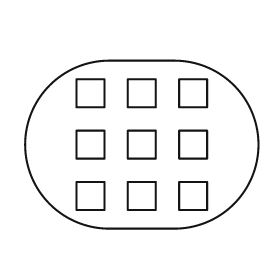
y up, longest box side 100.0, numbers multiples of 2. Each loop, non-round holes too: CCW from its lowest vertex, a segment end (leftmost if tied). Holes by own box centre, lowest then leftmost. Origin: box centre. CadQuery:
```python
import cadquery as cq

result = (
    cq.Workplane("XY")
    .moveTo(-14.0, -36.0)
    .lineTo(14.0, -36.0)
    .threePointArc((50.0, 0.0), (14.0, 36.0))
    .lineTo(-14.0, 36.0)
    .threePointArc((-50.0, 0.0), (-14.0, -36.0))
    .close()
    .moveTo(-28.0, -28.0)
    .lineTo(-16.0, -28.0)
    .lineTo(-16.0, -16.0)
    .lineTo(-28.0, -16.0)
    .close()
    .moveTo(-6.0, -28.0)
    .lineTo(6.0, -28.0)
    .lineTo(6.0, -16.0)
    .lineTo(-6.0, -16.0)
    .close()
    .moveTo(16.0, -28.0)
    .lineTo(28.0, -28.0)
    .lineTo(28.0, -16.0)
    .lineTo(16.0, -16.0)
    .close()
    .moveTo(-28.0, -6.0)
    .lineTo(-16.0, -6.0)
    .lineTo(-16.0, 6.0)
    .lineTo(-28.0, 6.0)
    .close()
    .moveTo(-6.0, -6.0)
    .lineTo(6.0, -6.0)
    .lineTo(6.0, 6.0)
    .lineTo(-6.0, 6.0)
    .close()
    .moveTo(16.0, -6.0)
    .lineTo(28.0, -6.0)
    .lineTo(28.0, 6.0)
    .lineTo(16.0, 6.0)
    .close()
    .moveTo(-28.0, 16.0)
    .lineTo(-16.0, 16.0)
    .lineTo(-16.0, 28.0)
    .lineTo(-28.0, 28.0)
    .close()
    .moveTo(-6.0, 16.0)
    .lineTo(6.0, 16.0)
    .lineTo(6.0, 28.0)
    .lineTo(-6.0, 28.0)
    .close()
    .moveTo(16.0, 16.0)
    .lineTo(28.0, 16.0)
    .lineTo(28.0, 28.0)
    .lineTo(16.0, 28.0)
    .close()
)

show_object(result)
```